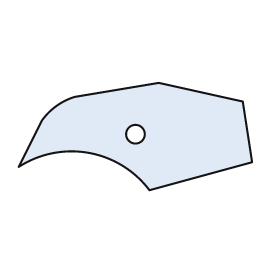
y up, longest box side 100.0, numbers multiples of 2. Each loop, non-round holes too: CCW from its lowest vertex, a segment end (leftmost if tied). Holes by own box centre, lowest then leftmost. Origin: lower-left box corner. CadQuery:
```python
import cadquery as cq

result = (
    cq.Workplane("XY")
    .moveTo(56.0, 0.0)
    .lineTo(100.0, 12.0)
    .lineTo(96.0, 38.0)
    .lineTo(60.0, 46.0)
    .lineTo(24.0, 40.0)
    .threePointArc((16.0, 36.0), (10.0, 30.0))
    .lineTo(0.0, 10.0)
    .threePointArc((30.0, 16.0), (56.0, 0.0))
    .close()
    .moveTo(50.0, 24.0)
    .circle(4.0)
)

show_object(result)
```